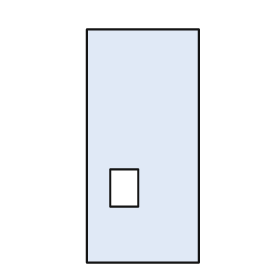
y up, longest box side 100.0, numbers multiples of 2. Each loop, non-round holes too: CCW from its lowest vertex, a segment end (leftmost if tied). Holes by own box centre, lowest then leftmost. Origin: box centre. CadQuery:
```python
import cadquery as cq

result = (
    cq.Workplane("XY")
    .moveTo(-24.0, -50.0)
    .lineTo(24.0, -50.0)
    .lineTo(24.0, 50.0)
    .lineTo(-24.0, 50.0)
    .close()
    .moveTo(-14.0, -26.0)
    .lineTo(-2.0, -26.0)
    .lineTo(-2.0, -10.0)
    .lineTo(-14.0, -10.0)
    .close()
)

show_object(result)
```